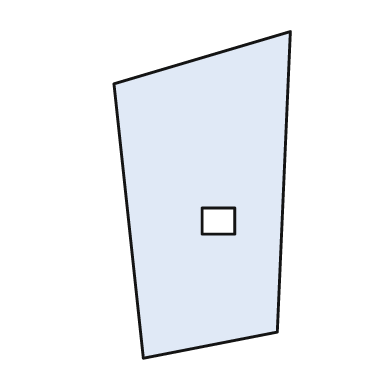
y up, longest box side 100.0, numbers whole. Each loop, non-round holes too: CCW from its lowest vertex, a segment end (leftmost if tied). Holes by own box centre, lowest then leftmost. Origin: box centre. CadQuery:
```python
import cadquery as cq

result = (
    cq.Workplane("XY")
    .moveTo(-18.0, -50.0)
    .lineTo(23.0, -42.0)
    .lineTo(27.0, 50.0)
    .lineTo(-27.0, 34.0)
    .close()
    .moveTo(0.0, -12.0)
    .lineTo(10.0, -12.0)
    .lineTo(10.0, -4.0)
    .lineTo(0.0, -4.0)
    .close()
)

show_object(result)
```